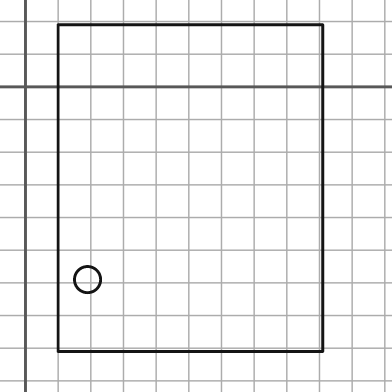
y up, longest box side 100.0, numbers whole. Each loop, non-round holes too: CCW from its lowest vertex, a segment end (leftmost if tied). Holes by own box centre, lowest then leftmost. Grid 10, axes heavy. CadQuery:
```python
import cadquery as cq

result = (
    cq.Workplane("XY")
    .moveTo(10.0, -81.0)
    .lineTo(91.0, -81.0)
    .lineTo(91.0, 19.0)
    .lineTo(10.0, 19.0)
    .close()
    .moveTo(19.0, -59.0)
    .circle(4.0)
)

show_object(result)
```